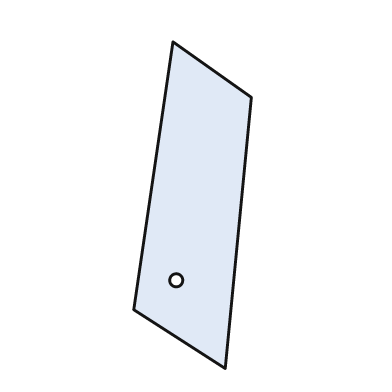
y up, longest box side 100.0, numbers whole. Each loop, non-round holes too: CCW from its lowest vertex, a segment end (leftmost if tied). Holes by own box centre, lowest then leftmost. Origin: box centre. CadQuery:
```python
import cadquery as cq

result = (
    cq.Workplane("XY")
    .moveTo(10.0, -50.0)
    .lineTo(18.0, 33.0)
    .lineTo(-6.0, 50.0)
    .lineTo(-18.0, -32.0)
    .close()
    .moveTo(-5.0, -23.0)
    .circle(2.0)
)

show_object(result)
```